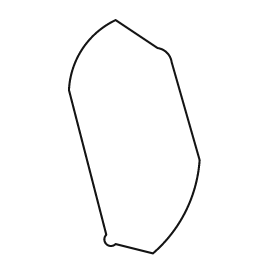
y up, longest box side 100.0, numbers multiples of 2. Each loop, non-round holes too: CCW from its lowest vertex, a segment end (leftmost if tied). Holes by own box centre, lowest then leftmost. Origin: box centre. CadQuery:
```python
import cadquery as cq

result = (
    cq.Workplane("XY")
    .moveTo(8.0, -50.0)
    .threePointArc((22.0, -32.0), (28.0, -10.0))
    .lineTo(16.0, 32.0)
    .threePointArc((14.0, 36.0), (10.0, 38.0))
    .lineTo(-8.0, 50.0)
    .threePointArc((-22.0, 38.0), (-28.0, 20.0))
    .lineTo(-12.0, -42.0)
    .threePointArc((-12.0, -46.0), (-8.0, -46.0))
    .close()
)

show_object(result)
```